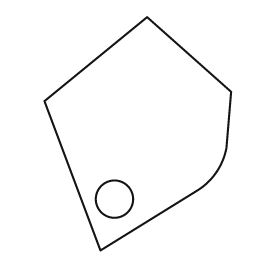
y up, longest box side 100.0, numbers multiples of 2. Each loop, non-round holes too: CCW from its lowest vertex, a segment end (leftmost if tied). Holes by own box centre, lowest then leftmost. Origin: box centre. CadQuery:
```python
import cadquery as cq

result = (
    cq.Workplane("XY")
    .moveTo(-16.0, -50.0)
    .lineTo(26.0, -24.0)
    .threePointArc((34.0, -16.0), (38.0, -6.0))
    .lineTo(40.0, 18.0)
    .lineTo(4.0, 50.0)
    .lineTo(-40.0, 14.0)
    .close()
    .moveTo(-10.0, -28.0)
    .circle(8.0)
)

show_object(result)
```